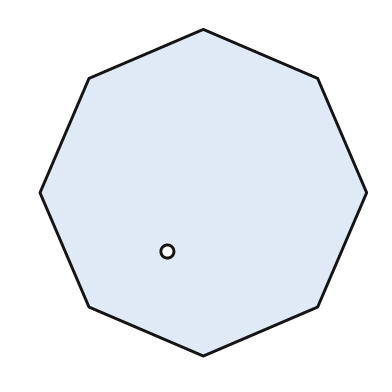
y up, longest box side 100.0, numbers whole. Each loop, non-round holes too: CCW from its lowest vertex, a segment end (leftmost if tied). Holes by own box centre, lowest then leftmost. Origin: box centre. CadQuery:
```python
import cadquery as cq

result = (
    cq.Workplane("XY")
    .moveTo(0.0, -50.0)
    .lineTo(35.0, -35.0)
    .lineTo(50.0, 0.0)
    .lineTo(35.0, 35.0)
    .lineTo(0.0, 50.0)
    .lineTo(-35.0, 35.0)
    .lineTo(-50.0, 0.0)
    .lineTo(-35.0, -35.0)
    .close()
    .moveTo(-11.0, -18.0)
    .circle(2.0)
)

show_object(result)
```